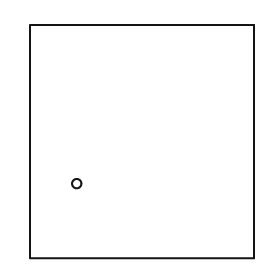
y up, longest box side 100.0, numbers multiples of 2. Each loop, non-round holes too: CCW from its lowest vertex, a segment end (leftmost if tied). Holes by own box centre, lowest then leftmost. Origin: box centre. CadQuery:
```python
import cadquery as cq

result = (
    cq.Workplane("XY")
    .moveTo(-48.0, -50.0)
    .lineTo(48.0, -50.0)
    .lineTo(48.0, 50.0)
    .lineTo(-48.0, 50.0)
    .close()
    .moveTo(-28.0, -18.0)
    .circle(2.0)
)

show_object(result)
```